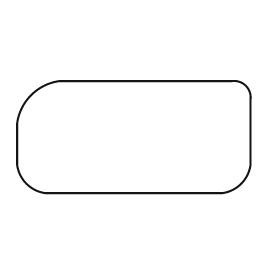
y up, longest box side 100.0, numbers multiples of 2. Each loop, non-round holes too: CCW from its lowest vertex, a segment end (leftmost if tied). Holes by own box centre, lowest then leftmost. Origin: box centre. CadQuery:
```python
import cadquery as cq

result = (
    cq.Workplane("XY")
    .moveTo(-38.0, -24.0)
    .lineTo(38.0, -24.0)
    .threePointArc((46.0, -20.0), (50.0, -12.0))
    .lineTo(50.0, 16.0)
    .threePointArc((48.0, 22.0), (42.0, 24.0))
    .lineTo(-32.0, 24.0)
    .threePointArc((-44.0, 18.0), (-50.0, 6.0))
    .lineTo(-50.0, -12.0)
    .threePointArc((-46.0, -20.0), (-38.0, -24.0))
    .close()
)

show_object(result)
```